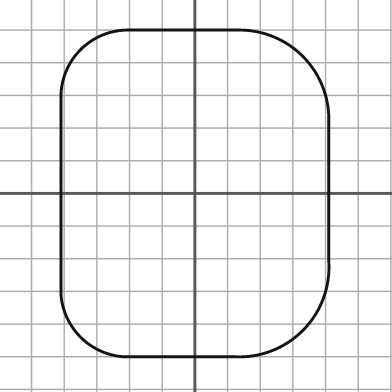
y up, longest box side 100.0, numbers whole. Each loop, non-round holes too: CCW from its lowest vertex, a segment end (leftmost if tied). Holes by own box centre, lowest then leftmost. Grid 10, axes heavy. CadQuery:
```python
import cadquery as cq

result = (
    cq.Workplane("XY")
    .moveTo(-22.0, -50.0)
    .lineTo(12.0, -50.0)
    .threePointArc((33.0, -42.0), (41.0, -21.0))
    .lineTo(41.0, 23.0)
    .threePointArc((33.0, 42.0), (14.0, 50.0))
    .lineTo(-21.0, 50.0)
    .threePointArc((-35.0, 44.0), (-41.0, 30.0))
    .lineTo(-41.0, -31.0)
    .threePointArc((-35.0, -44.0), (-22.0, -50.0))
    .close()
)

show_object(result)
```